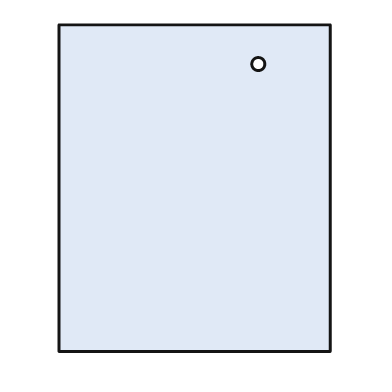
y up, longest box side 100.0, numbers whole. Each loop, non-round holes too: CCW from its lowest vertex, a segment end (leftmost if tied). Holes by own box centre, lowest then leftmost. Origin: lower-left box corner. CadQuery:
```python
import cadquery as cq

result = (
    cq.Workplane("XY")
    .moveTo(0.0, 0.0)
    .lineTo(83.0, 0.0)
    .lineTo(83.0, 100.0)
    .lineTo(0.0, 100.0)
    .close()
    .moveTo(61.0, 88.0)
    .circle(2.0)
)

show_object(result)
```